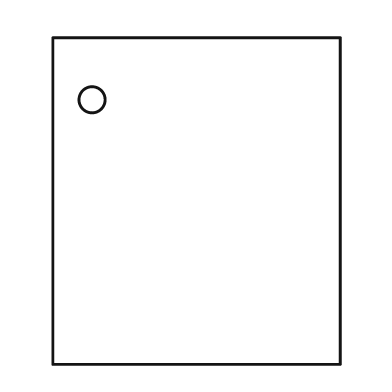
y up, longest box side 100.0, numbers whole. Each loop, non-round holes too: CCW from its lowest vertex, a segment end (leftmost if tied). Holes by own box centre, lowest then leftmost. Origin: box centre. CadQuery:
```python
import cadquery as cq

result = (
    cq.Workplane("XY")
    .moveTo(-44.0, -50.0)
    .lineTo(44.0, -50.0)
    .lineTo(44.0, 50.0)
    .lineTo(-44.0, 50.0)
    .close()
    .moveTo(-32.0, 31.0)
    .circle(4.0)
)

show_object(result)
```